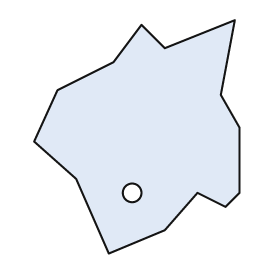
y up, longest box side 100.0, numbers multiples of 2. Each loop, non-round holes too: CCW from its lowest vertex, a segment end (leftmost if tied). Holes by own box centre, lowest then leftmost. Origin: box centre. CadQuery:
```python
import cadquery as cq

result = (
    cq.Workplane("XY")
    .moveTo(-12.0, -50.0)
    .lineTo(12.0, -40.0)
    .lineTo(26.0, -24.0)
    .lineTo(38.0, -30.0)
    .lineTo(44.0, -24.0)
    .lineTo(44.0, 4.0)
    .lineTo(36.0, 18.0)
    .lineTo(42.0, 50.0)
    .lineTo(12.0, 38.0)
    .lineTo(2.0, 48.0)
    .lineTo(-10.0, 32.0)
    .lineTo(-34.0, 20.0)
    .lineTo(-44.0, -2.0)
    .lineTo(-26.0, -18.0)
    .close()
    .moveTo(-2.0, -24.0)
    .circle(4.0)
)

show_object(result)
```